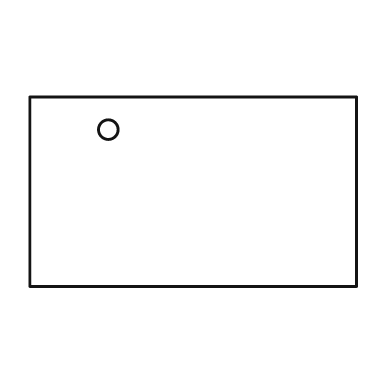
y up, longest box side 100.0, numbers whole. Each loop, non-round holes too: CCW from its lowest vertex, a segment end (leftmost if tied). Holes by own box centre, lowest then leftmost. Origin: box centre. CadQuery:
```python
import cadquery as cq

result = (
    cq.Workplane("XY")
    .moveTo(-50.0, -29.0)
    .lineTo(50.0, -29.0)
    .lineTo(50.0, 29.0)
    .lineTo(-50.0, 29.0)
    .close()
    .moveTo(-26.0, 19.0)
    .circle(3.0)
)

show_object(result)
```